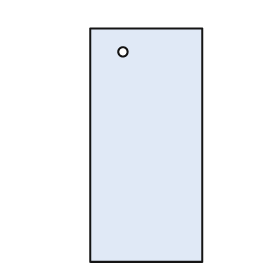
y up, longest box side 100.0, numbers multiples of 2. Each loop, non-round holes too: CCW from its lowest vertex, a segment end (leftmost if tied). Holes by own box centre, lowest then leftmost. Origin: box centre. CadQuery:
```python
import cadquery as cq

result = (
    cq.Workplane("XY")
    .moveTo(-24.0, -50.0)
    .lineTo(24.0, -50.0)
    .lineTo(24.0, 50.0)
    .lineTo(-24.0, 50.0)
    .close()
    .moveTo(-10.0, 40.0)
    .circle(2.0)
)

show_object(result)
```